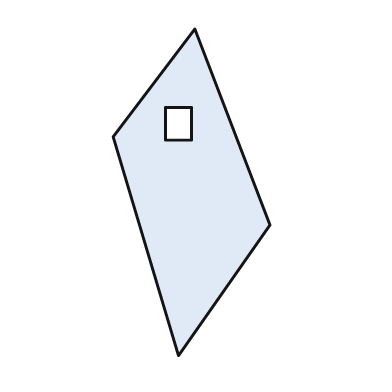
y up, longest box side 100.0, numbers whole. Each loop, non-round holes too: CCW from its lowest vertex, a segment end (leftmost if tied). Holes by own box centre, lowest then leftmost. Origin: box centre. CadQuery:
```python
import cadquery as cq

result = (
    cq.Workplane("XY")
    .moveTo(-4.0, -50.0)
    .lineTo(24.0, -10.0)
    .lineTo(1.0, 50.0)
    .lineTo(-24.0, 17.0)
    .close()
    .moveTo(-8.0, 16.0)
    .lineTo(0.0, 16.0)
    .lineTo(0.0, 26.0)
    .lineTo(-8.0, 26.0)
    .close()
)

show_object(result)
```